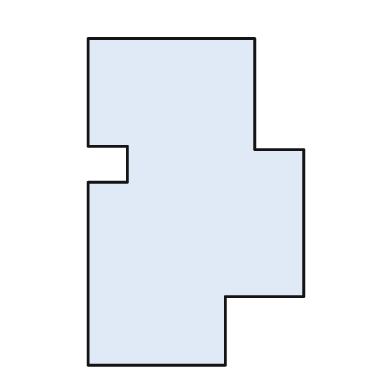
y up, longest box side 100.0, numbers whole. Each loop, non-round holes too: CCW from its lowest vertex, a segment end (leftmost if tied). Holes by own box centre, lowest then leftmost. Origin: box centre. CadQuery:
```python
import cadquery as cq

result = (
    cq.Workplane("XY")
    .moveTo(-33.0, -50.0)
    .lineTo(9.0, -50.0)
    .lineTo(9.0, -29.0)
    .lineTo(33.0, -29.0)
    .lineTo(33.0, 16.0)
    .lineTo(18.0, 16.0)
    .lineTo(18.0, 50.0)
    .lineTo(-33.0, 50.0)
    .lineTo(-33.0, 17.0)
    .lineTo(-21.0, 17.0)
    .lineTo(-21.0, 6.0)
    .lineTo(-33.0, 6.0)
    .close()
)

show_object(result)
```